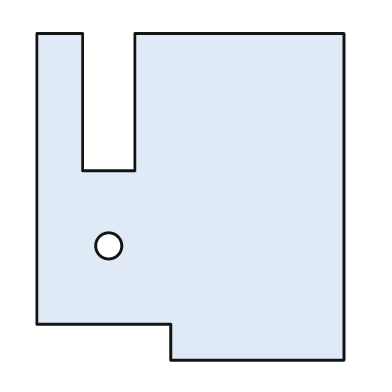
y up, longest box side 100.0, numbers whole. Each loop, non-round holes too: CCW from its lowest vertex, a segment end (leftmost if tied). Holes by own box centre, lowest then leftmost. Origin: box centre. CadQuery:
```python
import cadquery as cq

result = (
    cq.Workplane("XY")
    .moveTo(-6.0, -50.0)
    .lineTo(47.0, -50.0)
    .lineTo(47.0, 50.0)
    .lineTo(-17.0, 50.0)
    .lineTo(-17.0, 8.0)
    .lineTo(-33.0, 8.0)
    .lineTo(-33.0, 50.0)
    .lineTo(-47.0, 50.0)
    .lineTo(-47.0, -39.0)
    .lineTo(-6.0, -39.0)
    .close()
    .moveTo(-25.0, -15.0)
    .circle(4.0)
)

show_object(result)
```